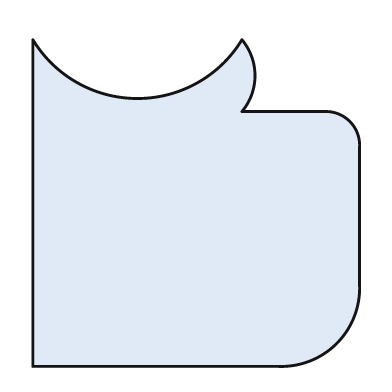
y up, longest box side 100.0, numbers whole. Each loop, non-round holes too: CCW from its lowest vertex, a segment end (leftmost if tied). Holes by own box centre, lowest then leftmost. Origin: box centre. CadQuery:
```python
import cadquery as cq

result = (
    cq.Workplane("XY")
    .moveTo(-50.0, -50.0)
    .lineTo(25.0, -50.0)
    .threePointArc((43.0, -43.0), (50.0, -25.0))
    .lineTo(50.0, 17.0)
    .threePointArc((47.0, 25.0), (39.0, 28.0))
    .lineTo(14.0, 28.0)
    .threePointArc((18.0, 39.0), (14.0, 50.0))
    .threePointArc((-18.0, 32.0), (-50.0, 50.0))
    .close()
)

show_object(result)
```